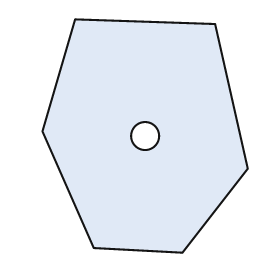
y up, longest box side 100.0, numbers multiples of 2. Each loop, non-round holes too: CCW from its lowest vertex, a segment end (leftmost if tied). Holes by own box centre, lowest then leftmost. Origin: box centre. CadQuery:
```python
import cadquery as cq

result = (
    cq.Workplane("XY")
    .moveTo(16.0, -50.0)
    .lineTo(44.0, -14.0)
    .lineTo(30.0, 48.0)
    .lineTo(-30.0, 50.0)
    .lineTo(-44.0, 2.0)
    .lineTo(-22.0, -48.0)
    .close()
    .moveTo(0.0, 0.0)
    .circle(6.0)
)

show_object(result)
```